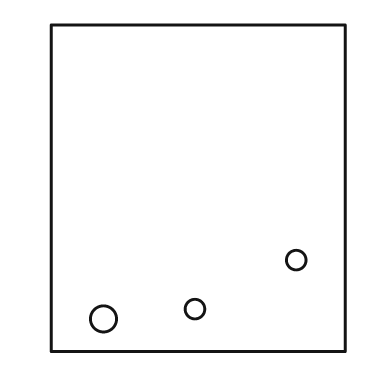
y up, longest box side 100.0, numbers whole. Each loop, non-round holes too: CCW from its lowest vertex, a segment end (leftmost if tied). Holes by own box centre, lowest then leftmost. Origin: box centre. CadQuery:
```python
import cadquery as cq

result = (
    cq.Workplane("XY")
    .moveTo(-45.0, -50.0)
    .lineTo(45.0, -50.0)
    .lineTo(45.0, 50.0)
    .lineTo(-45.0, 50.0)
    .close()
    .moveTo(-29.0, -40.0)
    .circle(4.0)
    .moveTo(-1.0, -37.0)
    .circle(3.0)
    .moveTo(30.0, -22.0)
    .circle(3.0)
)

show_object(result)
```